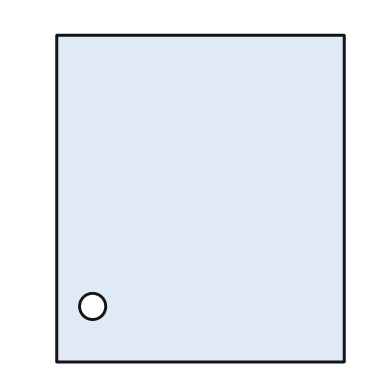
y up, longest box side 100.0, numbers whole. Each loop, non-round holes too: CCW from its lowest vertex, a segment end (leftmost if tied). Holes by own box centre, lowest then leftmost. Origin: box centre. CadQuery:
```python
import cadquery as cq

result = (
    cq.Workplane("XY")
    .moveTo(-44.0, -50.0)
    .lineTo(44.0, -50.0)
    .lineTo(44.0, 50.0)
    .lineTo(-44.0, 50.0)
    .close()
    .moveTo(-33.0, -33.0)
    .circle(4.0)
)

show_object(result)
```